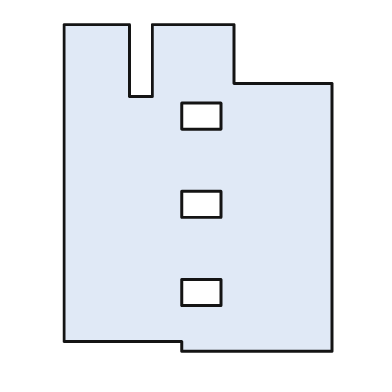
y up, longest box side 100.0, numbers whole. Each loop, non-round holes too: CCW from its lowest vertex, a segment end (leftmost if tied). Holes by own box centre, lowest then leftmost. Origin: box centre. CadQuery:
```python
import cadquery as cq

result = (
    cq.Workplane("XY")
    .moveTo(-5.0, -50.0)
    .lineTo(41.0, -50.0)
    .lineTo(41.0, 32.0)
    .lineTo(11.0, 32.0)
    .lineTo(11.0, 50.0)
    .lineTo(-14.0, 50.0)
    .lineTo(-14.0, 28.0)
    .lineTo(-21.0, 28.0)
    .lineTo(-21.0, 50.0)
    .lineTo(-41.0, 50.0)
    .lineTo(-41.0, -47.0)
    .lineTo(-5.0, -47.0)
    .close()
    .moveTo(-5.0, -36.0)
    .lineTo(7.0, -36.0)
    .lineTo(7.0, -28.0)
    .lineTo(-5.0, -28.0)
    .close()
    .moveTo(-5.0, -9.0)
    .lineTo(7.0, -9.0)
    .lineTo(7.0, -1.0)
    .lineTo(-5.0, -1.0)
    .close()
    .moveTo(-5.0, 18.0)
    .lineTo(7.0, 18.0)
    .lineTo(7.0, 26.0)
    .lineTo(-5.0, 26.0)
    .close()
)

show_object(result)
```